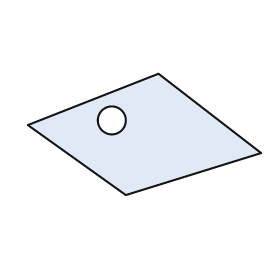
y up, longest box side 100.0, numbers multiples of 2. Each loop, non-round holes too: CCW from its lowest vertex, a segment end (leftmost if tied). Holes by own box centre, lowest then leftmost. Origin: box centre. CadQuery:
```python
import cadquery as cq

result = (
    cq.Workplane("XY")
    .moveTo(-8.0, -26.0)
    .lineTo(50.0, -8.0)
    .lineTo(6.0, 26.0)
    .lineTo(-50.0, 4.0)
    .close()
    .moveTo(-14.0, 6.0)
    .circle(6.0)
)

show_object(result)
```